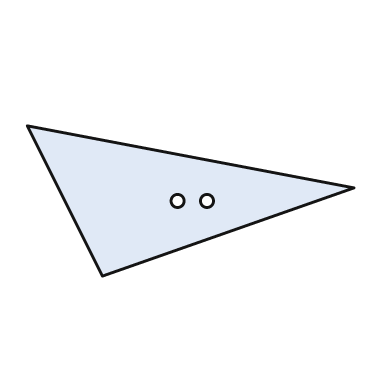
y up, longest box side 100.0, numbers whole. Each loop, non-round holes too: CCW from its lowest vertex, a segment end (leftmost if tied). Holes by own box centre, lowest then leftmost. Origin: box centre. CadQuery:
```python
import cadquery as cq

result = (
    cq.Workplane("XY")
    .moveTo(-27.0, -23.0)
    .lineTo(50.0, 4.0)
    .lineTo(-50.0, 23.0)
    .close()
    .moveTo(-4.0, 0.0)
    .circle(2.0)
    .moveTo(5.0, 0.0)
    .circle(2.0)
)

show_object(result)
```